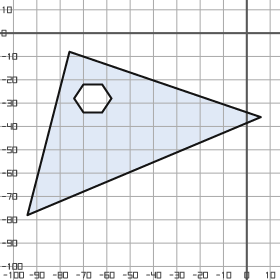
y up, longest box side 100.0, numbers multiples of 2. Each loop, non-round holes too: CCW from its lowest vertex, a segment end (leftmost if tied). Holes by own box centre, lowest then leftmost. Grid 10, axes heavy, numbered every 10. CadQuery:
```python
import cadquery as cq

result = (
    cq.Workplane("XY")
    .moveTo(-94.0, -78.0)
    .lineTo(6.0, -36.0)
    .lineTo(-76.0, -8.0)
    .close()
    .moveTo(-70.0, -34.0)
    .lineTo(-62.0, -34.0)
    .lineTo(-58.0, -28.0)
    .lineTo(-62.0, -22.0)
    .lineTo(-70.0, -22.0)
    .lineTo(-74.0, -28.0)
    .close()
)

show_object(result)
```